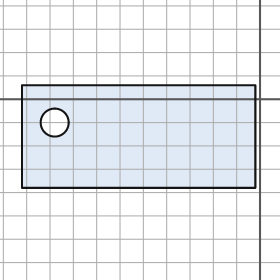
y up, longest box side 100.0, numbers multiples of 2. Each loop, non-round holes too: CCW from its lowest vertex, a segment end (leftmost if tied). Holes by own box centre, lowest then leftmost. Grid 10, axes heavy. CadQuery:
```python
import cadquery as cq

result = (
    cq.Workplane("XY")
    .moveTo(-102.0, -38.0)
    .lineTo(-2.0, -38.0)
    .lineTo(-2.0, 6.0)
    .lineTo(-102.0, 6.0)
    .close()
    .moveTo(-88.0, -10.0)
    .circle(6.0)
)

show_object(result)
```